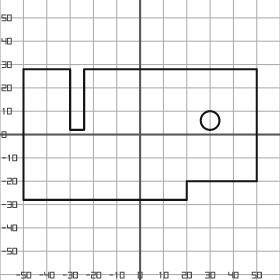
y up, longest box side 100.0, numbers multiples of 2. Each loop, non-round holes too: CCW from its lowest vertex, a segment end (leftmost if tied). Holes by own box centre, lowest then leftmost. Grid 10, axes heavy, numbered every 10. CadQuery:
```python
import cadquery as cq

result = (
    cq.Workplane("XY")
    .moveTo(-50.0, -28.0)
    .lineTo(20.0, -28.0)
    .lineTo(20.0, -20.0)
    .lineTo(50.0, -20.0)
    .lineTo(50.0, 28.0)
    .lineTo(-24.0, 28.0)
    .lineTo(-24.0, 2.0)
    .lineTo(-30.0, 2.0)
    .lineTo(-30.0, 28.0)
    .lineTo(-50.0, 28.0)
    .close()
    .moveTo(30.0, 6.0)
    .circle(4.0)
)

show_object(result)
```